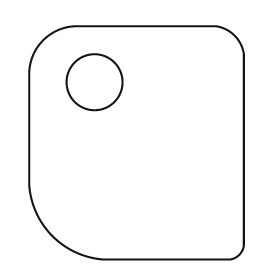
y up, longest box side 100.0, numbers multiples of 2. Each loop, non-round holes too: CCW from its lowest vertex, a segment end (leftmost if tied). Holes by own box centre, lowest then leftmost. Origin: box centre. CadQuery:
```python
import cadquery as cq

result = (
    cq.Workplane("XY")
    .moveTo(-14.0, -50.0)
    .lineTo(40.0, -50.0)
    .threePointArc((44.0, -48.0), (46.0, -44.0))
    .lineTo(46.0, 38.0)
    .threePointArc((42.0, 46.0), (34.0, 50.0))
    .lineTo(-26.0, 50.0)
    .threePointArc((-40.0, 44.0), (-46.0, 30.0))
    .lineTo(-46.0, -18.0)
    .threePointArc((-36.0, -40.0), (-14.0, -50.0))
    .close()
    .moveTo(-18.0, 26.0)
    .circle(12.0)
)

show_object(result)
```